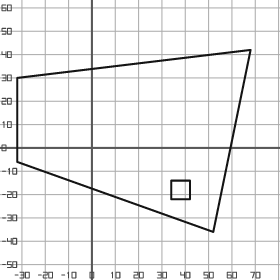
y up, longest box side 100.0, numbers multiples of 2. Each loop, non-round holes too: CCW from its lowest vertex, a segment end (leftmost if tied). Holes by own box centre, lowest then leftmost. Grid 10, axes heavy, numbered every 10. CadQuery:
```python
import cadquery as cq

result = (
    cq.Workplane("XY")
    .moveTo(52.0, -36.0)
    .lineTo(68.0, 42.0)
    .lineTo(-32.0, 30.0)
    .lineTo(-32.0, -6.0)
    .close()
    .moveTo(34.0, -22.0)
    .lineTo(42.0, -22.0)
    .lineTo(42.0, -14.0)
    .lineTo(34.0, -14.0)
    .close()
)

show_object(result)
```